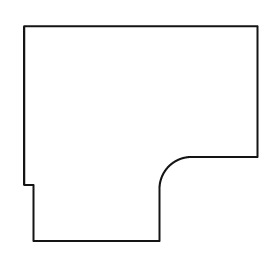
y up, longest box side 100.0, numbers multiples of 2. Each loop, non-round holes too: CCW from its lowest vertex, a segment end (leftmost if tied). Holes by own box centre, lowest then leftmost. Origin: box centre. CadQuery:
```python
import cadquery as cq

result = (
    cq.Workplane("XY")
    .moveTo(-46.0, -46.0)
    .lineTo(8.0, -46.0)
    .lineTo(8.0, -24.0)
    .threePointArc((12.0, -14.0), (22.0, -10.0))
    .lineTo(50.0, -10.0)
    .lineTo(50.0, 46.0)
    .lineTo(-50.0, 46.0)
    .lineTo(-50.0, -22.0)
    .lineTo(-46.0, -22.0)
    .close()
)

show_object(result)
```